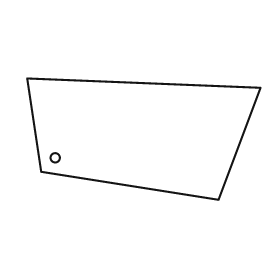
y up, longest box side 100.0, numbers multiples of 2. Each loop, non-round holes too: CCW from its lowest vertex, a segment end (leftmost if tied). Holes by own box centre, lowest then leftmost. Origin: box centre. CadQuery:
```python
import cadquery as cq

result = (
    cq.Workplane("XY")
    .moveTo(32.0, -26.0)
    .lineTo(50.0, 22.0)
    .lineTo(-50.0, 26.0)
    .lineTo(-44.0, -14.0)
    .close()
    .moveTo(-38.0, -8.0)
    .circle(2.0)
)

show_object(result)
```